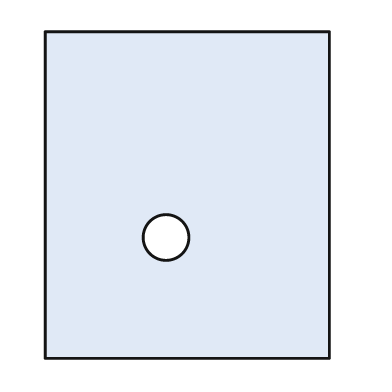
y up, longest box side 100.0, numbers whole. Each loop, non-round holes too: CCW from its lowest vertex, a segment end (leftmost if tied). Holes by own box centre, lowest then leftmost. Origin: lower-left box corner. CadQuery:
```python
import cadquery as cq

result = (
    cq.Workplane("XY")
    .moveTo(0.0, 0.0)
    .lineTo(87.0, 0.0)
    .lineTo(87.0, 100.0)
    .lineTo(0.0, 100.0)
    .close()
    .moveTo(37.0, 37.0)
    .circle(7.0)
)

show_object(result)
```